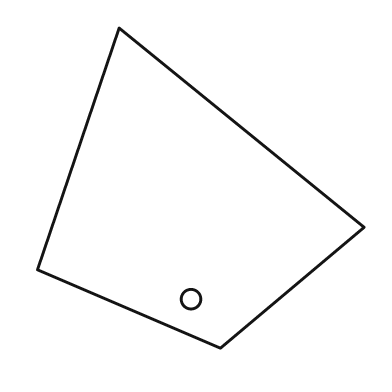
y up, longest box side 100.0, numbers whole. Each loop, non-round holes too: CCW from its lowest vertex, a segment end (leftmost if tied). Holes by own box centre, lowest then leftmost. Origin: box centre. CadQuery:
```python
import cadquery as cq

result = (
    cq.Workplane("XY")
    .moveTo(6.0, -49.0)
    .lineTo(50.0, -12.0)
    .lineTo(-25.0, 49.0)
    .lineTo(-50.0, -25.0)
    .close()
    .moveTo(-3.0, -34.0)
    .circle(3.0)
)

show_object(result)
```